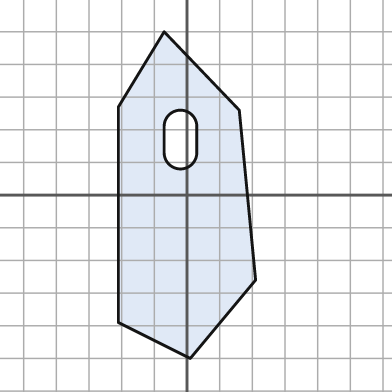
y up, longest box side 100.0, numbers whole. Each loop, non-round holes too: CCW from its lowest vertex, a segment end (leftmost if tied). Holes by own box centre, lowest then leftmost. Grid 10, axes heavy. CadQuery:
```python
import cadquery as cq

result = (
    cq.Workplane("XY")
    .moveTo(1.0, -50.0)
    .lineTo(21.0, -26.0)
    .lineTo(16.0, 26.0)
    .lineTo(-7.0, 50.0)
    .lineTo(-21.0, 27.0)
    .lineTo(-21.0, -39.0)
    .close()
    .moveTo(-7.0, 13.0)
    .threePointArc((-2.0, 8.0), (3.0, 13.0))
    .lineTo(3.0, 21.0)
    .threePointArc((-2.0, 26.0), (-7.0, 21.0))
    .close()
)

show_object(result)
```